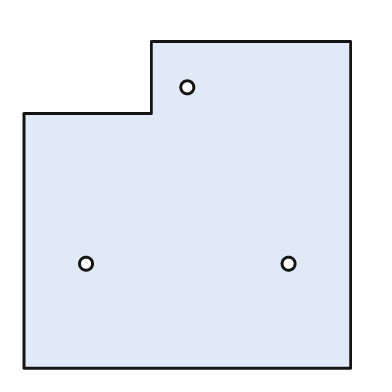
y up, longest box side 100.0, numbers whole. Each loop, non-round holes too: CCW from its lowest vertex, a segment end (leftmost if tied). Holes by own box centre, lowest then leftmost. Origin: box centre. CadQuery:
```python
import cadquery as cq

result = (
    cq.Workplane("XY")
    .moveTo(-50.0, -50.0)
    .lineTo(50.0, -50.0)
    .lineTo(50.0, 50.0)
    .lineTo(-11.0, 50.0)
    .lineTo(-11.0, 28.0)
    .lineTo(-50.0, 28.0)
    .close()
    .moveTo(-31.0, -18.0)
    .circle(2.0)
    .moveTo(31.0, -18.0)
    .circle(2.0)
    .moveTo(0.0, 36.0)
    .circle(2.0)
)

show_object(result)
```